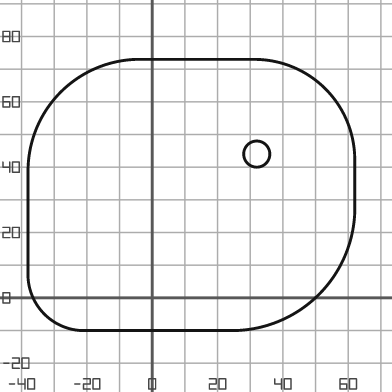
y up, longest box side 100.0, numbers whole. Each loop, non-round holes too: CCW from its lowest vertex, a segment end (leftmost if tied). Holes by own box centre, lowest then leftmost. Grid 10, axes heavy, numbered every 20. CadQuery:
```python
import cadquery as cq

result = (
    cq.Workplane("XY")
    .moveTo(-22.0, -10.0)
    .lineTo(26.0, -10.0)
    .threePointArc((51.0, 1.0), (62.0, 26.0))
    .lineTo(62.0, 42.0)
    .threePointArc((53.0, 64.0), (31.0, 73.0))
    .lineTo(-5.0, 73.0)
    .threePointArc((-28.0, 63.0), (-38.0, 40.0))
    .lineTo(-38.0, 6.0)
    .threePointArc((-33.0, -5.0), (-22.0, -10.0))
    .close()
    .moveTo(32.0, 44.0)
    .circle(4.0)
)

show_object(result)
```